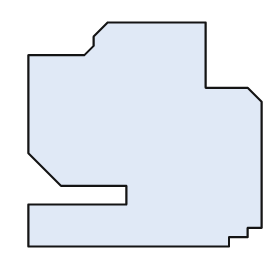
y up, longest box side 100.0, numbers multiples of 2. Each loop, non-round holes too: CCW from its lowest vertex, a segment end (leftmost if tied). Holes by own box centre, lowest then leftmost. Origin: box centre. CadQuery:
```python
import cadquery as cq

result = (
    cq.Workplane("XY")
    .moveTo(-50.0, -48.0)
    .lineTo(36.0, -48.0)
    .lineTo(36.0, -44.0)
    .lineTo(44.0, -44.0)
    .lineTo(44.0, -40.0)
    .lineTo(50.0, -40.0)
    .lineTo(50.0, 14.0)
    .lineTo(44.0, 20.0)
    .lineTo(26.0, 20.0)
    .lineTo(26.0, 48.0)
    .lineTo(-16.0, 48.0)
    .lineTo(-22.0, 42.0)
    .lineTo(-22.0, 38.0)
    .lineTo(-26.0, 34.0)
    .lineTo(-50.0, 34.0)
    .lineTo(-50.0, -8.0)
    .lineTo(-36.0, -22.0)
    .lineTo(-8.0, -22.0)
    .lineTo(-8.0, -30.0)
    .lineTo(-50.0, -30.0)
    .close()
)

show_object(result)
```